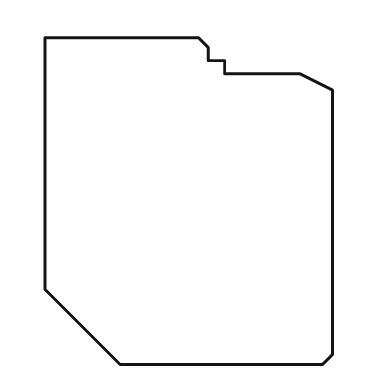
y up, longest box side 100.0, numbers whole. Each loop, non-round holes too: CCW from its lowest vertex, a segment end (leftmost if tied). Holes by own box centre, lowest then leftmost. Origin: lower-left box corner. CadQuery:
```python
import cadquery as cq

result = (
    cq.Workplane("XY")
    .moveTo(23.0, 0.0)
    .lineTo(85.0, 0.0)
    .lineTo(88.0, 3.0)
    .lineTo(88.0, 84.0)
    .lineTo(78.0, 89.0)
    .lineTo(55.0, 89.0)
    .lineTo(55.0, 93.0)
    .lineTo(50.0, 93.0)
    .lineTo(50.0, 97.0)
    .lineTo(47.0, 100.0)
    .lineTo(0.0, 100.0)
    .lineTo(0.0, 23.0)
    .close()
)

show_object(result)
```